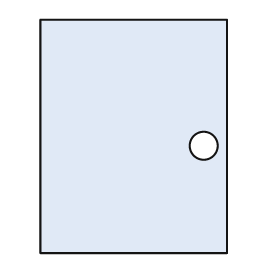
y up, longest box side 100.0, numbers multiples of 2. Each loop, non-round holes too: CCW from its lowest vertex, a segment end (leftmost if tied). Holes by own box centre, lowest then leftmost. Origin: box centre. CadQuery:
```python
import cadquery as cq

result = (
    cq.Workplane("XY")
    .moveTo(-40.0, -50.0)
    .lineTo(40.0, -50.0)
    .lineTo(40.0, 50.0)
    .lineTo(-40.0, 50.0)
    .close()
    .moveTo(30.0, -4.0)
    .circle(6.0)
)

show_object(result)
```